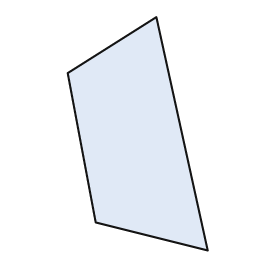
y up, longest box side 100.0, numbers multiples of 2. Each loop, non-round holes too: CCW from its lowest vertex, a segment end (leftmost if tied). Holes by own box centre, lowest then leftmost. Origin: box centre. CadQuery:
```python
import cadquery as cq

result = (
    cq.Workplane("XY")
    .moveTo(30.0, -50.0)
    .lineTo(8.0, 50.0)
    .lineTo(-30.0, 26.0)
    .lineTo(-18.0, -38.0)
    .close()
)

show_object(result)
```